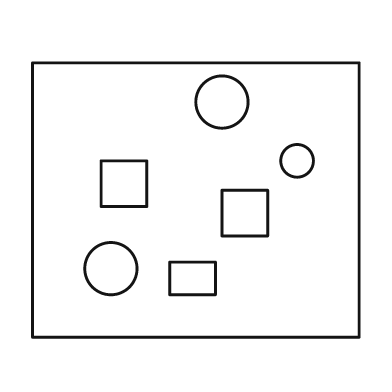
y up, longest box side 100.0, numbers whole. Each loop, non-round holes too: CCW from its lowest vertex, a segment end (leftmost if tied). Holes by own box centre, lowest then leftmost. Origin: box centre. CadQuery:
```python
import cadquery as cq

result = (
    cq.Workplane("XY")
    .moveTo(-50.0, -42.0)
    .lineTo(50.0, -42.0)
    .lineTo(50.0, 42.0)
    .lineTo(-50.0, 42.0)
    .close()
    .moveTo(-8.0, -29.0)
    .lineTo(6.0, -29.0)
    .lineTo(6.0, -19.0)
    .lineTo(-8.0, -19.0)
    .close()
    .moveTo(-26.0, -21.0)
    .circle(8.0)
    .moveTo(8.0, -11.0)
    .lineTo(22.0, -11.0)
    .lineTo(22.0, 3.0)
    .lineTo(8.0, 3.0)
    .close()
    .moveTo(-29.0, -2.0)
    .lineTo(-15.0, -2.0)
    .lineTo(-15.0, 12.0)
    .lineTo(-29.0, 12.0)
    .close()
    .moveTo(31.0, 12.0)
    .circle(5.0)
    .moveTo(8.0, 30.0)
    .circle(8.0)
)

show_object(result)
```